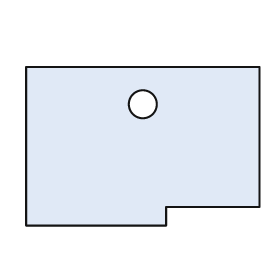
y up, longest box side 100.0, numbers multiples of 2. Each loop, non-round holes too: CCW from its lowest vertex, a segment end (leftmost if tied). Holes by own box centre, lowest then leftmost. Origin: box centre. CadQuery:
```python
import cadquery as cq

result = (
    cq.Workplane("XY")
    .moveTo(-50.0, -34.0)
    .lineTo(10.0, -34.0)
    .lineTo(10.0, -26.0)
    .lineTo(50.0, -26.0)
    .lineTo(50.0, 34.0)
    .lineTo(-50.0, 34.0)
    .close()
    .moveTo(0.0, 18.0)
    .circle(6.0)
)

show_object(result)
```